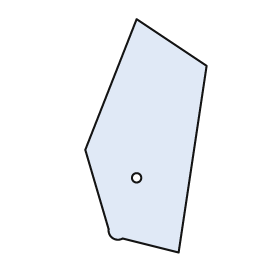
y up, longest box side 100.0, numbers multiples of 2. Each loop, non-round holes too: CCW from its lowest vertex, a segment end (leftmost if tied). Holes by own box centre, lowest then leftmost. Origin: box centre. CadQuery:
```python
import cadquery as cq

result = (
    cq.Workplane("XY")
    .moveTo(14.0, -50.0)
    .lineTo(26.0, 30.0)
    .lineTo(-4.0, 50.0)
    .lineTo(-26.0, -6.0)
    .lineTo(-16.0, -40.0)
    .threePointArc((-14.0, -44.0), (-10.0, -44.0))
    .close()
    .moveTo(-4.0, -18.0)
    .circle(2.0)
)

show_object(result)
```